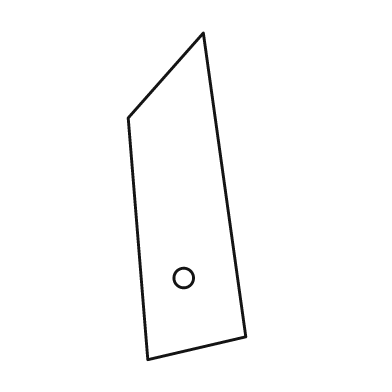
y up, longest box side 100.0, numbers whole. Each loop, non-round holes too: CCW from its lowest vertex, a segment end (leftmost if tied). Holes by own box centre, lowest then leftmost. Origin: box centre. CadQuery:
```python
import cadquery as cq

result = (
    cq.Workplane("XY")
    .moveTo(-12.0, -50.0)
    .lineTo(18.0, -43.0)
    .lineTo(5.0, 50.0)
    .lineTo(-18.0, 24.0)
    .close()
    .moveTo(-1.0, -25.0)
    .circle(3.0)
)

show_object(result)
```